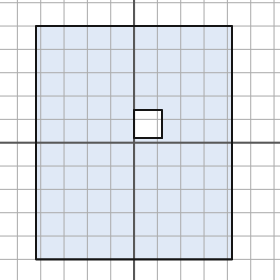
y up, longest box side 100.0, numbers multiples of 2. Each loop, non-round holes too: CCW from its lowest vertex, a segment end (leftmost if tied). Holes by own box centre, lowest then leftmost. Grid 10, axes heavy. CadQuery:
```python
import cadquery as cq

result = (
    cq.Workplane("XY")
    .moveTo(-42.0, -50.0)
    .lineTo(42.0, -50.0)
    .lineTo(42.0, 50.0)
    .lineTo(-42.0, 50.0)
    .close()
    .moveTo(0.0, 2.0)
    .lineTo(12.0, 2.0)
    .lineTo(12.0, 14.0)
    .lineTo(0.0, 14.0)
    .close()
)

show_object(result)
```